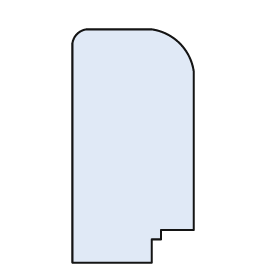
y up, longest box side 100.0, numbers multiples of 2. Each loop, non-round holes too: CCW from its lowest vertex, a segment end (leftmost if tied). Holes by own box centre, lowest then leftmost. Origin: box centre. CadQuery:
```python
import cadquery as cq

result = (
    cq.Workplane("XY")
    .moveTo(-26.0, -50.0)
    .lineTo(8.0, -50.0)
    .lineTo(8.0, -40.0)
    .lineTo(12.0, -40.0)
    .lineTo(12.0, -36.0)
    .lineTo(26.0, -36.0)
    .lineTo(26.0, 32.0)
    .threePointArc((20.0, 44.0), (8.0, 50.0))
    .lineTo(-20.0, 50.0)
    .threePointArc((-24.0, 48.0), (-26.0, 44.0))
    .close()
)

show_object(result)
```